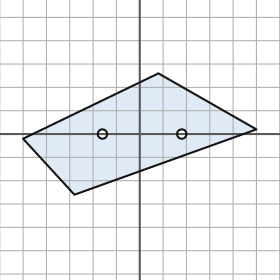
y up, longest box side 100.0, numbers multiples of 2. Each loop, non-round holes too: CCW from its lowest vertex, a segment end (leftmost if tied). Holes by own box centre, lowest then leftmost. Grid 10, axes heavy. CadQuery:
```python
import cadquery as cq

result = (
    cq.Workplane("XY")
    .moveTo(-28.0, -26.0)
    .lineTo(50.0, 2.0)
    .lineTo(8.0, 26.0)
    .lineTo(-50.0, -2.0)
    .close()
    .moveTo(-16.0, 0.0)
    .circle(2.0)
    .moveTo(18.0, 0.0)
    .circle(2.0)
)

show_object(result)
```